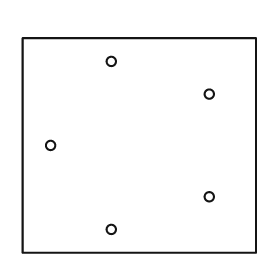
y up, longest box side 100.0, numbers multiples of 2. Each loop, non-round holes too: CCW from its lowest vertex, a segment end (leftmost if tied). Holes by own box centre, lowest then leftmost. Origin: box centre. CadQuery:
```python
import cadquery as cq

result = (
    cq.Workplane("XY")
    .moveTo(-50.0, -46.0)
    .lineTo(50.0, -46.0)
    .lineTo(50.0, 46.0)
    .lineTo(-50.0, 46.0)
    .close()
    .moveTo(-12.0, -36.0)
    .circle(2.0)
    .moveTo(30.0, -22.0)
    .circle(2.0)
    .moveTo(-38.0, 0.0)
    .circle(2.0)
    .moveTo(30.0, 22.0)
    .circle(2.0)
    .moveTo(-12.0, 36.0)
    .circle(2.0)
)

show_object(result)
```